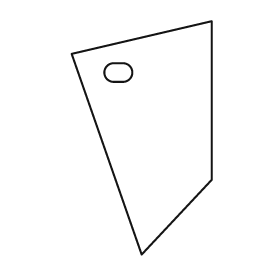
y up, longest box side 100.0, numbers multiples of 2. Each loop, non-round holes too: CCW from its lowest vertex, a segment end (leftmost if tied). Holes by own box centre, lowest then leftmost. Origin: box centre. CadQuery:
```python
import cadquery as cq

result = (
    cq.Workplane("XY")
    .moveTo(0.0, -50.0)
    .lineTo(30.0, -18.0)
    .lineTo(30.0, 50.0)
    .lineTo(-30.0, 36.0)
    .close()
    .moveTo(-12.0, 24.0)
    .lineTo(-8.0, 24.0)
    .threePointArc((-4.0, 28.0), (-8.0, 32.0))
    .lineTo(-12.0, 32.0)
    .threePointArc((-16.0, 28.0), (-12.0, 24.0))
    .close()
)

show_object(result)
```